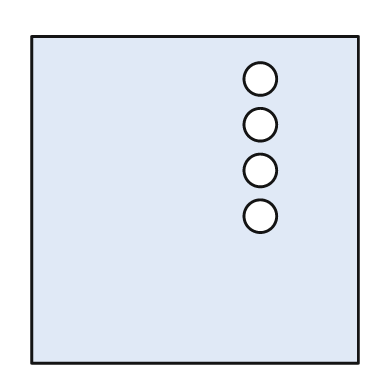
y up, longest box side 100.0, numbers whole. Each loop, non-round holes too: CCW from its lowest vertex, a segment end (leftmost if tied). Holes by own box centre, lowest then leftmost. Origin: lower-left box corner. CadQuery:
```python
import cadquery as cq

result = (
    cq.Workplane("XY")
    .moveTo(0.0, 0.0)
    .lineTo(100.0, 0.0)
    .lineTo(100.0, 100.0)
    .lineTo(0.0, 100.0)
    .close()
    .moveTo(70.0, 45.0)
    .circle(5.0)
    .moveTo(70.0, 59.0)
    .circle(5.0)
    .moveTo(70.0, 73.0)
    .circle(5.0)
    .moveTo(70.0, 87.0)
    .circle(5.0)
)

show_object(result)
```